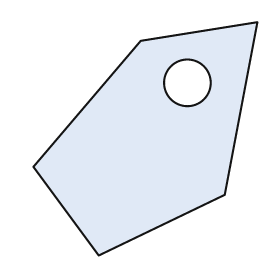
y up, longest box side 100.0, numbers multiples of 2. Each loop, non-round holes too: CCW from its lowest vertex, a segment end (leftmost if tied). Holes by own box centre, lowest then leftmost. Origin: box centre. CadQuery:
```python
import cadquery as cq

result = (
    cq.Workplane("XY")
    .moveTo(-20.0, -50.0)
    .lineTo(34.0, -24.0)
    .lineTo(48.0, 50.0)
    .lineTo(-2.0, 42.0)
    .lineTo(-48.0, -12.0)
    .close()
    .moveTo(18.0, 24.0)
    .circle(10.0)
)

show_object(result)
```